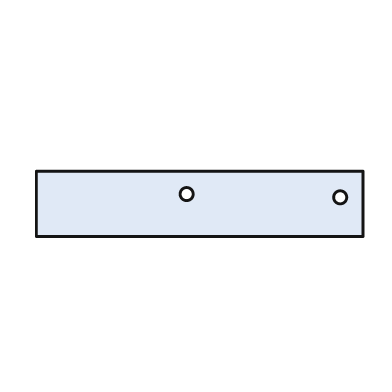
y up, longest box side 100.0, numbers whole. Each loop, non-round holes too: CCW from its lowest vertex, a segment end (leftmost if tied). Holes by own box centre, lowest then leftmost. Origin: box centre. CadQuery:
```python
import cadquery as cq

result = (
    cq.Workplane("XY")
    .moveTo(-50.0, -10.0)
    .lineTo(50.0, -10.0)
    .lineTo(50.0, 10.0)
    .lineTo(-50.0, 10.0)
    .close()
    .moveTo(43.0, 2.0)
    .circle(2.0)
    .moveTo(-4.0, 3.0)
    .circle(2.0)
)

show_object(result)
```